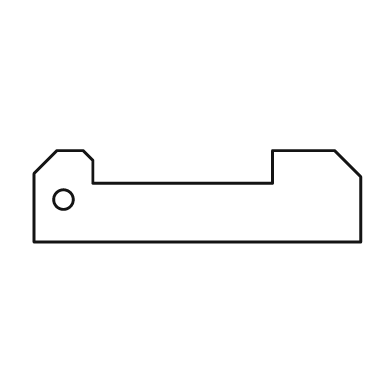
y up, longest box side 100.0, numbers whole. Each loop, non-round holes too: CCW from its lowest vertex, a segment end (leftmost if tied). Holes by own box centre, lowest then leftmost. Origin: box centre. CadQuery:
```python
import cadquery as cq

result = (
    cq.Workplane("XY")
    .moveTo(-50.0, -14.0)
    .lineTo(50.0, -14.0)
    .lineTo(50.0, 6.0)
    .lineTo(42.0, 14.0)
    .lineTo(23.0, 14.0)
    .lineTo(23.0, 4.0)
    .lineTo(-32.0, 4.0)
    .lineTo(-32.0, 11.0)
    .lineTo(-35.0, 14.0)
    .lineTo(-43.0, 14.0)
    .lineTo(-50.0, 7.0)
    .close()
    .moveTo(-41.0, -1.0)
    .circle(3.0)
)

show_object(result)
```